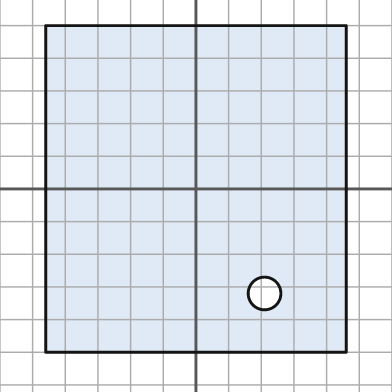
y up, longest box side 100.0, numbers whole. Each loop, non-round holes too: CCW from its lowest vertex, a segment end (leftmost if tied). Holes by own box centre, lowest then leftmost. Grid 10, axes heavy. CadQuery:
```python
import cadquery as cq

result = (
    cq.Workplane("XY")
    .moveTo(-46.0, -50.0)
    .lineTo(46.0, -50.0)
    .lineTo(46.0, 50.0)
    .lineTo(-46.0, 50.0)
    .close()
    .moveTo(21.0, -32.0)
    .circle(5.0)
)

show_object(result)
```